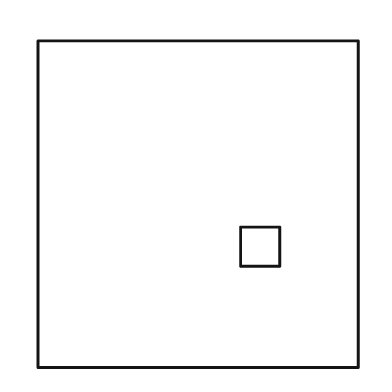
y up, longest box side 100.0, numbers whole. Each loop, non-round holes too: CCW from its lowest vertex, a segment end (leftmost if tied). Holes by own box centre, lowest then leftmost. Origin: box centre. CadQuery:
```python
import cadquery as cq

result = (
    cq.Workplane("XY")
    .moveTo(-49.0, -50.0)
    .lineTo(49.0, -50.0)
    .lineTo(49.0, 50.0)
    .lineTo(-49.0, 50.0)
    .close()
    .moveTo(13.0, -19.0)
    .lineTo(25.0, -19.0)
    .lineTo(25.0, -7.0)
    .lineTo(13.0, -7.0)
    .close()
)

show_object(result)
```